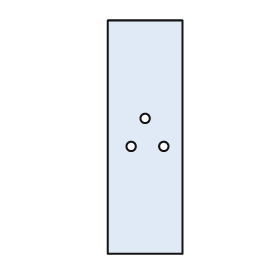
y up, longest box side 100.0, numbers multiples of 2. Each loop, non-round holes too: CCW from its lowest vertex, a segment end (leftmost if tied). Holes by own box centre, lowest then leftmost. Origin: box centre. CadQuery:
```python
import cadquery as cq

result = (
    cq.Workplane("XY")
    .moveTo(-16.0, -50.0)
    .lineTo(16.0, -50.0)
    .lineTo(16.0, 50.0)
    .lineTo(-16.0, 50.0)
    .close()
    .moveTo(-6.0, -4.0)
    .circle(2.0)
    .moveTo(8.0, -4.0)
    .circle(2.0)
    .moveTo(0.0, 8.0)
    .circle(2.0)
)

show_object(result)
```